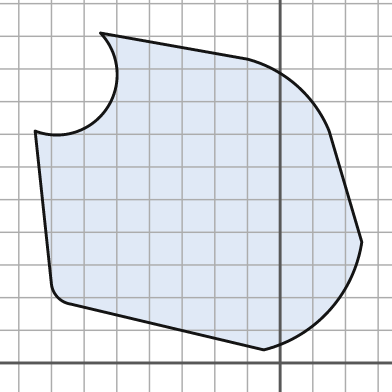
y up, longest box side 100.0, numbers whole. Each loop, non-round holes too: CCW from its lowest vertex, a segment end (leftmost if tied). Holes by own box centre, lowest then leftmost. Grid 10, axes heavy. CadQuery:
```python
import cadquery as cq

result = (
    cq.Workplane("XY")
    .moveTo(-5.0, 4.0)
    .threePointArc((15.0, 16.0), (25.0, 37.0))
    .lineTo(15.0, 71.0)
    .threePointArc((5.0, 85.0), (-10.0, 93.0))
    .lineTo(-55.0, 101.0)
    .threePointArc((-53.0, 78.0), (-75.0, 71.0))
    .lineTo(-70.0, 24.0)
    .threePointArc((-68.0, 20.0), (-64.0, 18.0))
    .close()
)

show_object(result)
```